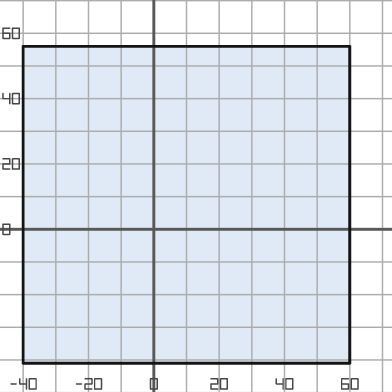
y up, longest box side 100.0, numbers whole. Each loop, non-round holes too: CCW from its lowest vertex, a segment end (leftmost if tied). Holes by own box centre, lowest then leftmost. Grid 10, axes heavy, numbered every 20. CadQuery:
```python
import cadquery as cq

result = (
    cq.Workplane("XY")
    .moveTo(-40.0, -41.0)
    .lineTo(60.0, -41.0)
    .lineTo(60.0, 56.0)
    .lineTo(-40.0, 56.0)
    .close()
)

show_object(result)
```